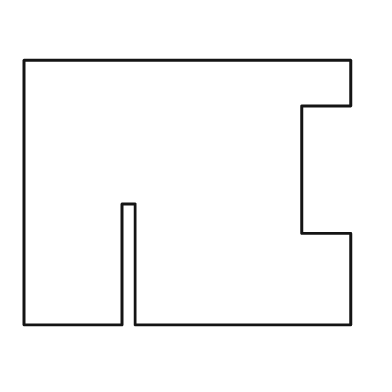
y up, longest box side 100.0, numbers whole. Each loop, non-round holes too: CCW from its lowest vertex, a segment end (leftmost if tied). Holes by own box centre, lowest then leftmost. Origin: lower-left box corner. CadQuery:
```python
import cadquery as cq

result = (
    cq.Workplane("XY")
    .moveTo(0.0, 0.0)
    .lineTo(30.0, 0.0)
    .lineTo(30.0, 37.0)
    .lineTo(34.0, 37.0)
    .lineTo(34.0, 0.0)
    .lineTo(100.0, 0.0)
    .lineTo(100.0, 28.0)
    .lineTo(85.0, 28.0)
    .lineTo(85.0, 67.0)
    .lineTo(100.0, 67.0)
    .lineTo(100.0, 81.0)
    .lineTo(0.0, 81.0)
    .close()
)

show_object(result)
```